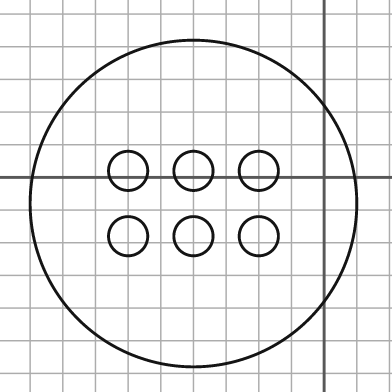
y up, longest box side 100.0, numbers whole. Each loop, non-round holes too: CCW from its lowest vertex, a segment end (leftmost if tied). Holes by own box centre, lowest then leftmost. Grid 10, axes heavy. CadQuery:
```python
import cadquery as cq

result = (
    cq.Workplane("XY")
    .moveTo(-40.0, -8.0)
    .circle(50.0)
    .moveTo(-60.0, -18.0)
    .circle(6.0)
    .moveTo(-40.0, -18.0)
    .circle(6.0)
    .moveTo(-20.0, -18.0)
    .circle(6.0)
    .moveTo(-60.0, 2.0)
    .circle(6.0)
    .moveTo(-40.0, 2.0)
    .circle(6.0)
    .moveTo(-20.0, 2.0)
    .circle(6.0)
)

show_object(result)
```